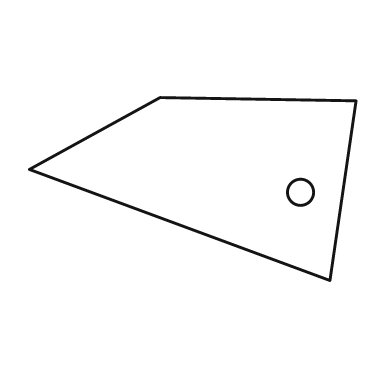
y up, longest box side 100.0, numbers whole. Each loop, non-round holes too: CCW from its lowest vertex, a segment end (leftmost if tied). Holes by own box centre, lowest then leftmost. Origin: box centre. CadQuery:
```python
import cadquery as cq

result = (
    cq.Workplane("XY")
    .moveTo(42.0, -28.0)
    .lineTo(50.0, 27.0)
    .lineTo(-10.0, 28.0)
    .lineTo(-50.0, 6.0)
    .close()
    .moveTo(33.0, -1.0)
    .circle(4.0)
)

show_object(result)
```